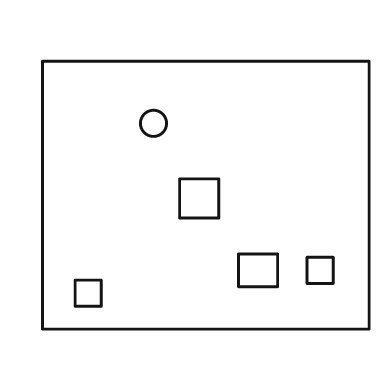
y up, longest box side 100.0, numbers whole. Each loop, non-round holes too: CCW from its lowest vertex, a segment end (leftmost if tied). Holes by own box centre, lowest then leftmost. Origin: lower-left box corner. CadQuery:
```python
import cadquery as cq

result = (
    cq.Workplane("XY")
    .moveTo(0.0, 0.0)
    .lineTo(100.0, 0.0)
    .lineTo(100.0, 82.0)
    .lineTo(0.0, 82.0)
    .close()
    .moveTo(10.0, 7.0)
    .lineTo(18.0, 7.0)
    .lineTo(18.0, 15.0)
    .lineTo(10.0, 15.0)
    .close()
    .moveTo(60.0, 13.0)
    .lineTo(72.0, 13.0)
    .lineTo(72.0, 23.0)
    .lineTo(60.0, 23.0)
    .close()
    .moveTo(81.0, 14.0)
    .lineTo(89.0, 14.0)
    .lineTo(89.0, 22.0)
    .lineTo(81.0, 22.0)
    .close()
    .moveTo(42.0, 34.0)
    .lineTo(54.0, 34.0)
    .lineTo(54.0, 46.0)
    .lineTo(42.0, 46.0)
    .close()
    .moveTo(34.0, 63.0)
    .circle(4.0)
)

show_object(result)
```